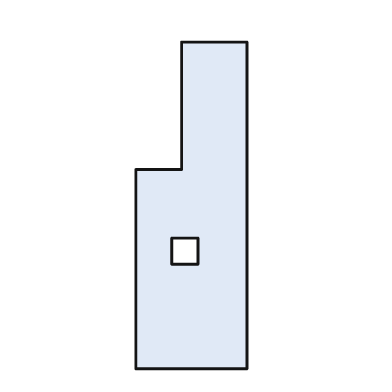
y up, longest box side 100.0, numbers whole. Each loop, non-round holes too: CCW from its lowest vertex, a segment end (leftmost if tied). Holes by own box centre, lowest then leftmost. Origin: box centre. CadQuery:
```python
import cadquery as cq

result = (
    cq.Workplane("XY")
    .moveTo(-17.0, -50.0)
    .lineTo(17.0, -50.0)
    .lineTo(17.0, 50.0)
    .lineTo(-3.0, 50.0)
    .lineTo(-3.0, 11.0)
    .lineTo(-17.0, 11.0)
    .close()
    .moveTo(-6.0, -18.0)
    .lineTo(2.0, -18.0)
    .lineTo(2.0, -10.0)
    .lineTo(-6.0, -10.0)
    .close()
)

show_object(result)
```